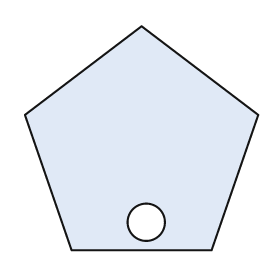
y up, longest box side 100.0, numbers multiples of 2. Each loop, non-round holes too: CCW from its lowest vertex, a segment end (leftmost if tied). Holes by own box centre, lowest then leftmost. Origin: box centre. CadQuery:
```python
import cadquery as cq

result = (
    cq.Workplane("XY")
    .moveTo(-30.0, -48.0)
    .lineTo(30.0, -48.0)
    .lineTo(50.0, 10.0)
    .lineTo(0.0, 48.0)
    .lineTo(-50.0, 10.0)
    .close()
    .moveTo(2.0, -36.0)
    .circle(8.0)
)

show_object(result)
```